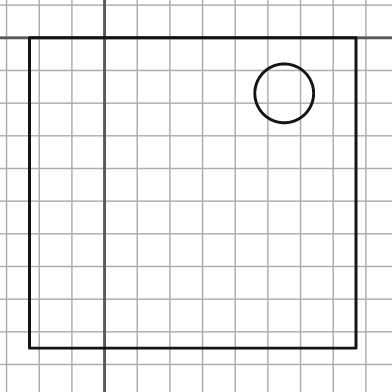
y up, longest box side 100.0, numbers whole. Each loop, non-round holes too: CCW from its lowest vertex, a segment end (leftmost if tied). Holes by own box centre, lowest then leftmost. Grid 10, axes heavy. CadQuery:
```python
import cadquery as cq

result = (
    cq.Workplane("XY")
    .moveTo(-23.0, -95.0)
    .lineTo(77.0, -95.0)
    .lineTo(77.0, 0.0)
    .lineTo(-23.0, 0.0)
    .close()
    .moveTo(55.0, -17.0)
    .circle(9.0)
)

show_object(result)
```